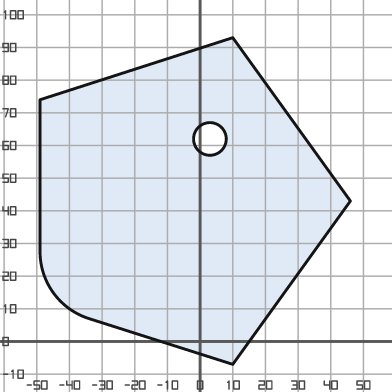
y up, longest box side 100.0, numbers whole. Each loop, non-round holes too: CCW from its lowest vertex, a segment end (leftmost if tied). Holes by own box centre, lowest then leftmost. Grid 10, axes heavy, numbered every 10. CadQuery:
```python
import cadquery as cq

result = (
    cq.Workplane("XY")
    .moveTo(10.0, -7.0)
    .lineTo(46.0, 43.0)
    .lineTo(10.0, 93.0)
    .lineTo(-49.0, 74.0)
    .lineTo(-49.0, 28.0)
    .threePointArc((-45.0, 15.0), (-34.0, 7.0))
    .close()
    .moveTo(3.0, 62.0)
    .circle(5.0)
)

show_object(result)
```